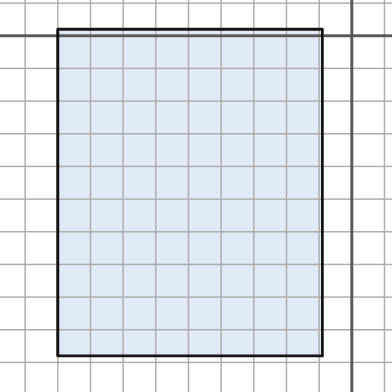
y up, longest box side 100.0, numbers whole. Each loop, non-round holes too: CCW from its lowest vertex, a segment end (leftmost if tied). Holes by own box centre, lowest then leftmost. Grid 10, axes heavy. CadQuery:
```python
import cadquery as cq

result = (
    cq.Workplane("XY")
    .moveTo(-90.0, -98.0)
    .lineTo(-9.0, -98.0)
    .lineTo(-9.0, 2.0)
    .lineTo(-90.0, 2.0)
    .close()
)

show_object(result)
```